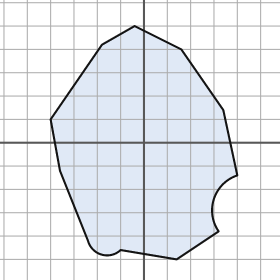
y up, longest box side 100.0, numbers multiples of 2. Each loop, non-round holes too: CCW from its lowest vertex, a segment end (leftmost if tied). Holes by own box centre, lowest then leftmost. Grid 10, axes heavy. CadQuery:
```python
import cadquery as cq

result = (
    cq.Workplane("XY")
    .moveTo(14.0, -50.0)
    .lineTo(32.0, -38.0)
    .threePointArc((30.0, -24.0), (40.0, -14.0))
    .lineTo(34.0, 14.0)
    .lineTo(16.0, 40.0)
    .lineTo(-4.0, 50.0)
    .lineTo(-18.0, 42.0)
    .lineTo(-40.0, 10.0)
    .lineTo(-36.0, -12.0)
    .lineTo(-24.0, -42.0)
    .threePointArc((-18.0, -48.0), (-10.0, -46.0))
    .close()
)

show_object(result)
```